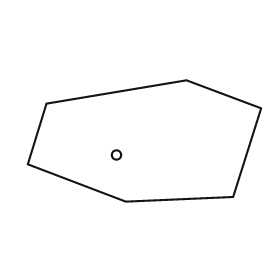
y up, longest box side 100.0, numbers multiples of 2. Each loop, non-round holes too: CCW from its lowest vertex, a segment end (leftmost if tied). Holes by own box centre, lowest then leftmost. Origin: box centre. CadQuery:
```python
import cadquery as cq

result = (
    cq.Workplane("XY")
    .moveTo(-8.0, -26.0)
    .lineTo(38.0, -24.0)
    .lineTo(50.0, 14.0)
    .lineTo(18.0, 26.0)
    .lineTo(-42.0, 16.0)
    .lineTo(-50.0, -10.0)
    .close()
    .moveTo(-12.0, -6.0)
    .circle(2.0)
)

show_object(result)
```